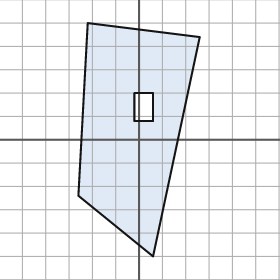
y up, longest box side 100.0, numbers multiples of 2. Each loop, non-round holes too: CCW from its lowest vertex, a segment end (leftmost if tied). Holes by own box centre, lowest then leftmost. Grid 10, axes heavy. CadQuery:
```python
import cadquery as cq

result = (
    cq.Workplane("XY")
    .moveTo(6.0, -50.0)
    .lineTo(26.0, 44.0)
    .lineTo(-22.0, 50.0)
    .lineTo(-26.0, -24.0)
    .close()
    .moveTo(-2.0, 8.0)
    .lineTo(6.0, 8.0)
    .lineTo(6.0, 20.0)
    .lineTo(-2.0, 20.0)
    .close()
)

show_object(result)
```